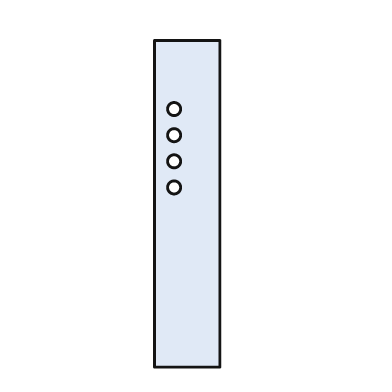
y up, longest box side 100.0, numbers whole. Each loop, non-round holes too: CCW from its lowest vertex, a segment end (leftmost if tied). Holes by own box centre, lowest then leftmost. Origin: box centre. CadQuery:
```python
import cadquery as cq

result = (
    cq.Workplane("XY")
    .moveTo(-10.0, -50.0)
    .lineTo(10.0, -50.0)
    .lineTo(10.0, 50.0)
    .lineTo(-10.0, 50.0)
    .close()
    .moveTo(-4.0, 5.0)
    .circle(2.0)
    .moveTo(-4.0, 13.0)
    .circle(2.0)
    .moveTo(-4.0, 21.0)
    .circle(2.0)
    .moveTo(-4.0, 29.0)
    .circle(2.0)
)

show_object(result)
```